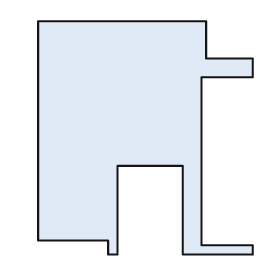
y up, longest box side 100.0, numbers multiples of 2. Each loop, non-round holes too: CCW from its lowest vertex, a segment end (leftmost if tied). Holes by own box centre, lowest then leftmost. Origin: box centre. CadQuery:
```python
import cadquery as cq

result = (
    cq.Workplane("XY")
    .moveTo(-16.0, -50.0)
    .lineTo(-12.0, -50.0)
    .lineTo(-12.0, -12.0)
    .lineTo(16.0, -12.0)
    .lineTo(16.0, -50.0)
    .lineTo(46.0, -50.0)
    .lineTo(46.0, -46.0)
    .lineTo(24.0, -46.0)
    .lineTo(24.0, 26.0)
    .lineTo(46.0, 26.0)
    .lineTo(46.0, 34.0)
    .lineTo(26.0, 34.0)
    .lineTo(26.0, 50.0)
    .lineTo(-46.0, 50.0)
    .lineTo(-46.0, -44.0)
    .lineTo(-16.0, -44.0)
    .close()
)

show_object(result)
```